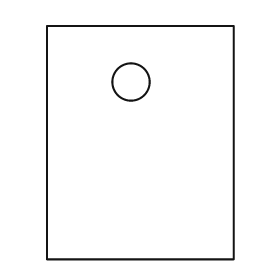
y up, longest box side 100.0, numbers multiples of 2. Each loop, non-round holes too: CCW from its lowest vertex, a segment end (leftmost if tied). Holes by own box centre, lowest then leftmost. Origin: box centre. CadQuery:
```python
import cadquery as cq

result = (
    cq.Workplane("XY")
    .moveTo(-40.0, -50.0)
    .lineTo(40.0, -50.0)
    .lineTo(40.0, 50.0)
    .lineTo(-40.0, 50.0)
    .close()
    .moveTo(-4.0, 26.0)
    .circle(8.0)
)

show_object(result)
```